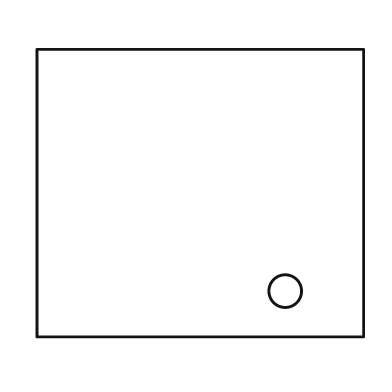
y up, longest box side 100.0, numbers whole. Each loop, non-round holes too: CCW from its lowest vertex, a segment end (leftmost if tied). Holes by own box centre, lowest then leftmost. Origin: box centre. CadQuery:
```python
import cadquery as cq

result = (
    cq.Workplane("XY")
    .moveTo(-50.0, -44.0)
    .lineTo(50.0, -44.0)
    .lineTo(50.0, 44.0)
    .lineTo(-50.0, 44.0)
    .close()
    .moveTo(26.0, -30.0)
    .circle(5.0)
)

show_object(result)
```